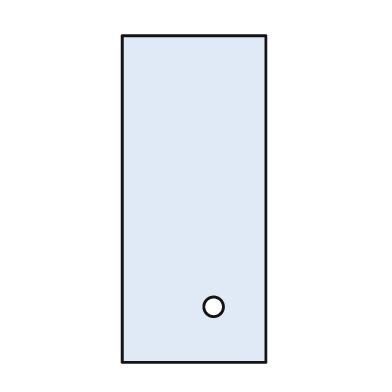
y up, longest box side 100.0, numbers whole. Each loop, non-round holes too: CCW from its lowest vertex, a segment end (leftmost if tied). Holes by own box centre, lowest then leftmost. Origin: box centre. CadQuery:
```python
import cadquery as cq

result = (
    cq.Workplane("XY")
    .moveTo(-22.0, -50.0)
    .lineTo(22.0, -50.0)
    .lineTo(22.0, 50.0)
    .lineTo(-22.0, 50.0)
    .close()
    .moveTo(6.0, -33.0)
    .circle(3.0)
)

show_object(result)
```